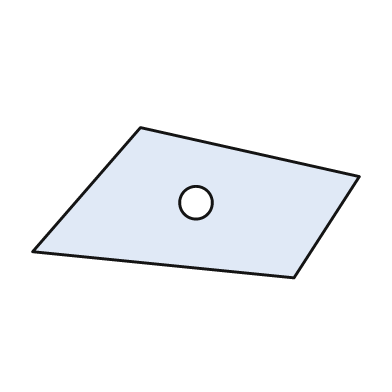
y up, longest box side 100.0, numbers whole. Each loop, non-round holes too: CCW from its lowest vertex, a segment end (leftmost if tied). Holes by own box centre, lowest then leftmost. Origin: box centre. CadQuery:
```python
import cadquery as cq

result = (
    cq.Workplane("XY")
    .moveTo(30.0, -23.0)
    .lineTo(50.0, 8.0)
    .lineTo(-17.0, 23.0)
    .lineTo(-50.0, -15.0)
    .close()
    .moveTo(0.0, 0.0)
    .circle(5.0)
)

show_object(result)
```